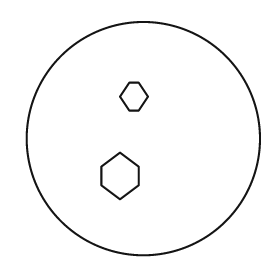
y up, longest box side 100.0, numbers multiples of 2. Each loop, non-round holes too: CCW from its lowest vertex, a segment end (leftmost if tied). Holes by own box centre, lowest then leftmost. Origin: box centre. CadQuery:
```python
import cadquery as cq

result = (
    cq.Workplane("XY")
    .moveTo(0.0, 0.0)
    .circle(50.0)
    .moveTo(-10.0, -26.0)
    .lineTo(-2.0, -20.0)
    .lineTo(-2.0, -12.0)
    .lineTo(-10.0, -6.0)
    .lineTo(-18.0, -12.0)
    .lineTo(-18.0, -20.0)
    .close()
    .moveTo(-6.0, 12.0)
    .lineTo(-2.0, 12.0)
    .lineTo(2.0, 18.0)
    .lineTo(-2.0, 24.0)
    .lineTo(-6.0, 24.0)
    .lineTo(-10.0, 18.0)
    .close()
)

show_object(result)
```